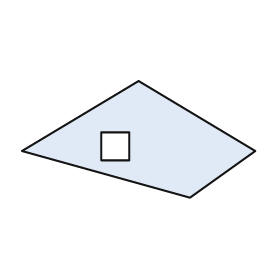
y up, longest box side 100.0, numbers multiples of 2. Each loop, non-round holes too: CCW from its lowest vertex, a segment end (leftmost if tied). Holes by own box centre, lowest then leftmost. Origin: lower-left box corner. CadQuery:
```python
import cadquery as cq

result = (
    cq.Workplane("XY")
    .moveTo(72.0, 0.0)
    .lineTo(100.0, 20.0)
    .lineTo(50.0, 50.0)
    .lineTo(0.0, 20.0)
    .close()
    .moveTo(34.0, 16.0)
    .lineTo(46.0, 16.0)
    .lineTo(46.0, 28.0)
    .lineTo(34.0, 28.0)
    .close()
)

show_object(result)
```